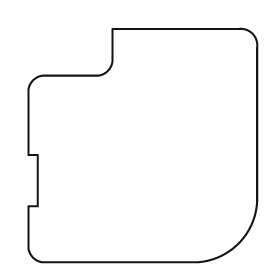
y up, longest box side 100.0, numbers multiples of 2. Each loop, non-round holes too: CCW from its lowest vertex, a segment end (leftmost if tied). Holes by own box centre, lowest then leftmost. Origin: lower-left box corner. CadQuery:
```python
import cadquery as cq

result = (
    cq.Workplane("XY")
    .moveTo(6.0, 0.0)
    .lineTo(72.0, 0.0)
    .threePointArc((90.0, 8.0), (98.0, 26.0))
    .lineTo(98.0, 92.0)
    .threePointArc((96.0, 98.0), (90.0, 100.0))
    .lineTo(36.0, 100.0)
    .lineTo(36.0, 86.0)
    .threePointArc((34.0, 82.0), (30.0, 80.0))
    .lineTo(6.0, 80.0)
    .threePointArc((2.0, 78.0), (0.0, 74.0))
    .lineTo(0.0, 46.0)
    .lineTo(4.0, 46.0)
    .lineTo(4.0, 24.0)
    .lineTo(0.0, 24.0)
    .lineTo(0.0, 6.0)
    .threePointArc((2.0, 2.0), (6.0, 0.0))
    .close()
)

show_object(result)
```